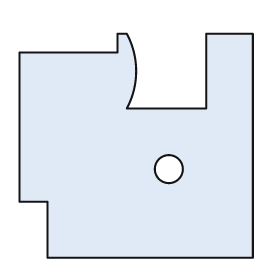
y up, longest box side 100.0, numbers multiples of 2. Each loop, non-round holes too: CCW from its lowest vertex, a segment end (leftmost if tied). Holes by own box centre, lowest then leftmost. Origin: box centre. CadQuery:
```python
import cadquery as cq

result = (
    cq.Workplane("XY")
    .moveTo(-38.0, -48.0)
    .lineTo(50.0, -48.0)
    .lineTo(50.0, 48.0)
    .lineTo(30.0, 48.0)
    .lineTo(30.0, 16.0)
    .lineTo(-4.0, 16.0)
    .threePointArc((0.0, 32.0), (-4.0, 48.0))
    .lineTo(-8.0, 48.0)
    .lineTo(-8.0, 40.0)
    .lineTo(-50.0, 40.0)
    .lineTo(-50.0, -24.0)
    .lineTo(-38.0, -24.0)
    .close()
    .moveTo(14.0, -10.0)
    .circle(6.0)
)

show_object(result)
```